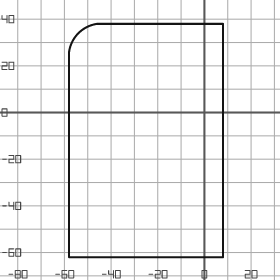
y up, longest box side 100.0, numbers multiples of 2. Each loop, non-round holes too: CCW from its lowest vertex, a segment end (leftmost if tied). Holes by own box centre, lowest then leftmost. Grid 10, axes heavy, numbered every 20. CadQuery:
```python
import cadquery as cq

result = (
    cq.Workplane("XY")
    .moveTo(-58.0, -62.0)
    .lineTo(8.0, -62.0)
    .lineTo(8.0, 38.0)
    .lineTo(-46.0, 38.0)
    .threePointArc((-54.0, 34.0), (-58.0, 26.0))
    .close()
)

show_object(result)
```